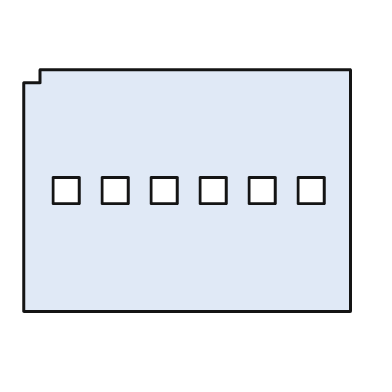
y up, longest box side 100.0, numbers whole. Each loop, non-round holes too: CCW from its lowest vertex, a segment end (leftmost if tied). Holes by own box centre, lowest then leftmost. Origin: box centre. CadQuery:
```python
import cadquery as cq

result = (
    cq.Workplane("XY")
    .moveTo(-50.0, -37.0)
    .lineTo(50.0, -37.0)
    .lineTo(50.0, 37.0)
    .lineTo(-45.0, 37.0)
    .lineTo(-45.0, 33.0)
    .lineTo(-50.0, 33.0)
    .close()
    .moveTo(-41.0, -4.0)
    .lineTo(-33.0, -4.0)
    .lineTo(-33.0, 4.0)
    .lineTo(-41.0, 4.0)
    .close()
    .moveTo(-26.0, -4.0)
    .lineTo(-18.0, -4.0)
    .lineTo(-18.0, 4.0)
    .lineTo(-26.0, 4.0)
    .close()
    .moveTo(-11.0, -4.0)
    .lineTo(-3.0, -4.0)
    .lineTo(-3.0, 4.0)
    .lineTo(-11.0, 4.0)
    .close()
    .moveTo(4.0, -4.0)
    .lineTo(12.0, -4.0)
    .lineTo(12.0, 4.0)
    .lineTo(4.0, 4.0)
    .close()
    .moveTo(19.0, -4.0)
    .lineTo(27.0, -4.0)
    .lineTo(27.0, 4.0)
    .lineTo(19.0, 4.0)
    .close()
    .moveTo(34.0, -4.0)
    .lineTo(42.0, -4.0)
    .lineTo(42.0, 4.0)
    .lineTo(34.0, 4.0)
    .close()
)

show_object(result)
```